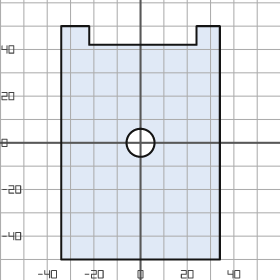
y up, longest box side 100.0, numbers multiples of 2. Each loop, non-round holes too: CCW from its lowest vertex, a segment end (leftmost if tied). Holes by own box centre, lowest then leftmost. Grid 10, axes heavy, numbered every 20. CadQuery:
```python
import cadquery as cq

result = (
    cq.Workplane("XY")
    .moveTo(-34.0, -50.0)
    .lineTo(34.0, -50.0)
    .lineTo(34.0, 50.0)
    .lineTo(24.0, 50.0)
    .lineTo(24.0, 42.0)
    .lineTo(-22.0, 42.0)
    .lineTo(-22.0, 50.0)
    .lineTo(-34.0, 50.0)
    .close()
    .moveTo(0.0, 0.0)
    .circle(6.0)
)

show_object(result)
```